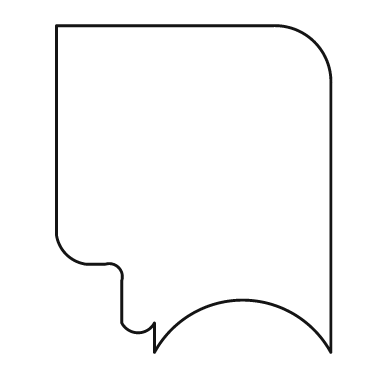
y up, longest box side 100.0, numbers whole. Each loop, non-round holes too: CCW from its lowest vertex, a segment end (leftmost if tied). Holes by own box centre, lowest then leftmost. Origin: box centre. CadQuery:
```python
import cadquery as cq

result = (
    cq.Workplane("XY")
    .moveTo(-12.0, -50.0)
    .threePointArc((15.0, -34.0), (42.0, -50.0))
    .lineTo(42.0, 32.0)
    .threePointArc((37.0, 45.0), (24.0, 50.0))
    .lineTo(-42.0, 50.0)
    .lineTo(-42.0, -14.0)
    .threePointArc((-39.0, -20.0), (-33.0, -23.0))
    .lineTo(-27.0, -23.0)
    .threePointArc((-23.0, -24.0), (-22.0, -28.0))
    .lineTo(-22.0, -41.0)
    .threePointArc((-17.0, -44.0), (-12.0, -41.0))
    .close()
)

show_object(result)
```